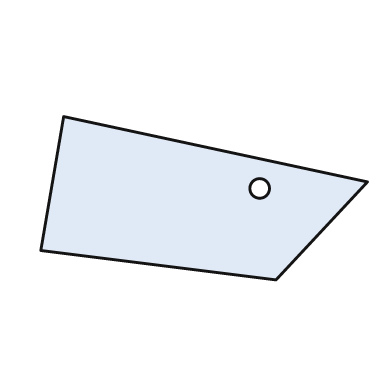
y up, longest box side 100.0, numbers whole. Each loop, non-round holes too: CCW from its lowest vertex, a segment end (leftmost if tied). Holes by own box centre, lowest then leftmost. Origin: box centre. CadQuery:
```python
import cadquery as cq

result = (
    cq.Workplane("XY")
    .moveTo(22.0, -25.0)
    .lineTo(50.0, 5.0)
    .lineTo(-43.0, 25.0)
    .lineTo(-50.0, -16.0)
    .close()
    .moveTo(17.0, 3.0)
    .circle(3.0)
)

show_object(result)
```